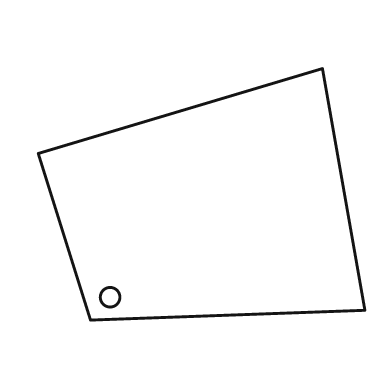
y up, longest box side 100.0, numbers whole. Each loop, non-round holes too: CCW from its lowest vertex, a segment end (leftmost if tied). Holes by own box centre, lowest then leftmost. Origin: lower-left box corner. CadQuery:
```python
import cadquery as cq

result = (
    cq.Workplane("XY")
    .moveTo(16.0, 0.0)
    .lineTo(100.0, 3.0)
    .lineTo(87.0, 77.0)
    .lineTo(0.0, 51.0)
    .close()
    .moveTo(22.0, 7.0)
    .circle(3.0)
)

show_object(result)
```